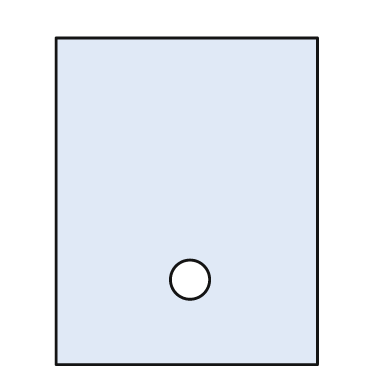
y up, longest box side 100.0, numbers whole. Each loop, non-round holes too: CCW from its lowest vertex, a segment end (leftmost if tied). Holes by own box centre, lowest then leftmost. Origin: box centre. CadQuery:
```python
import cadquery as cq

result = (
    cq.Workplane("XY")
    .moveTo(-40.0, -50.0)
    .lineTo(40.0, -50.0)
    .lineTo(40.0, 50.0)
    .lineTo(-40.0, 50.0)
    .close()
    .moveTo(1.0, -24.0)
    .circle(6.0)
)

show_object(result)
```